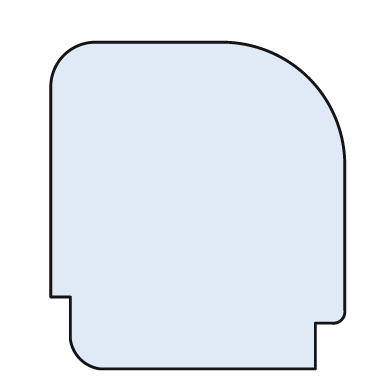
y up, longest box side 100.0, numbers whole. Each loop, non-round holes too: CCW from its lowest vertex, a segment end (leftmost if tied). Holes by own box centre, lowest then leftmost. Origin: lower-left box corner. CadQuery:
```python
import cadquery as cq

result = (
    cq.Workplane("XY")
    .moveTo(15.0, 0.0)
    .lineTo(81.0, 0.0)
    .lineTo(81.0, 14.0)
    .lineTo(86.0, 14.0)
    .threePointArc((89.0, 15.0), (90.0, 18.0))
    .lineTo(90.0, 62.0)
    .threePointArc((79.0, 89.0), (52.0, 100.0))
    .lineTo(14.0, 100.0)
    .threePointArc((4.0, 96.0), (0.0, 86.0))
    .lineTo(0.0, 22.0)
    .lineTo(6.0, 22.0)
    .lineTo(6.0, 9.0)
    .threePointArc((9.0, 3.0), (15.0, 0.0))
    .close()
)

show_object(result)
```